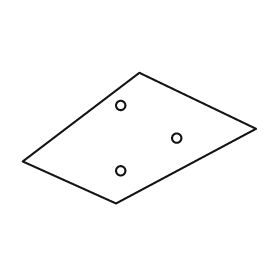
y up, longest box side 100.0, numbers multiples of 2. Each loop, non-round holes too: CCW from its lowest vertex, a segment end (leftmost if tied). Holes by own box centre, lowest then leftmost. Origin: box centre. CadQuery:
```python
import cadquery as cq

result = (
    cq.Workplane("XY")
    .moveTo(-10.0, -28.0)
    .lineTo(50.0, 4.0)
    .lineTo(0.0, 28.0)
    .lineTo(-50.0, -10.0)
    .close()
    .moveTo(-8.0, -14.0)
    .circle(2.0)
    .moveTo(16.0, 0.0)
    .circle(2.0)
    .moveTo(-8.0, 14.0)
    .circle(2.0)
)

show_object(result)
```